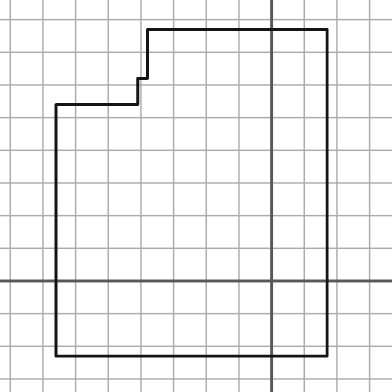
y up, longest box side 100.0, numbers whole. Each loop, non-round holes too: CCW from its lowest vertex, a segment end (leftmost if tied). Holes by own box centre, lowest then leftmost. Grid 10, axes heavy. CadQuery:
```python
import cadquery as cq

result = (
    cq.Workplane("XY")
    .moveTo(-66.0, -23.0)
    .lineTo(17.0, -23.0)
    .lineTo(17.0, 77.0)
    .lineTo(-38.0, 77.0)
    .lineTo(-38.0, 62.0)
    .lineTo(-41.0, 62.0)
    .lineTo(-41.0, 54.0)
    .lineTo(-66.0, 54.0)
    .close()
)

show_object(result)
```